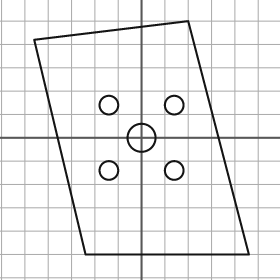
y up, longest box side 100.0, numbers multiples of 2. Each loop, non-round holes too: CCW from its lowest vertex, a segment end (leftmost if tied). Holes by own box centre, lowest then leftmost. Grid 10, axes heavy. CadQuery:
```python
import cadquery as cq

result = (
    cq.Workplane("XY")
    .moveTo(-24.0, -50.0)
    .lineTo(46.0, -50.0)
    .lineTo(20.0, 50.0)
    .lineTo(-46.0, 42.0)
    .close()
    .moveTo(-14.0, -14.0)
    .circle(4.0)
    .moveTo(14.0, -14.0)
    .circle(4.0)
    .moveTo(0.0, 0.0)
    .circle(6.0)
    .moveTo(-14.0, 14.0)
    .circle(4.0)
    .moveTo(14.0, 14.0)
    .circle(4.0)
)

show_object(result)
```